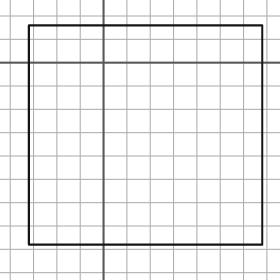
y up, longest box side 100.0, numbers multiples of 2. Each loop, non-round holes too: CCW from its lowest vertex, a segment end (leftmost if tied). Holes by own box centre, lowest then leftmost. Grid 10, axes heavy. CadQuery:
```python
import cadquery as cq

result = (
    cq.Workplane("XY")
    .moveTo(-32.0, -78.0)
    .lineTo(68.0, -78.0)
    .lineTo(68.0, 16.0)
    .lineTo(-32.0, 16.0)
    .close()
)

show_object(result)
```